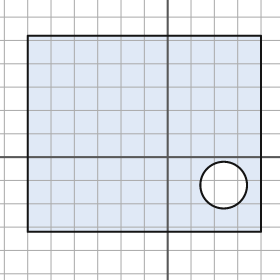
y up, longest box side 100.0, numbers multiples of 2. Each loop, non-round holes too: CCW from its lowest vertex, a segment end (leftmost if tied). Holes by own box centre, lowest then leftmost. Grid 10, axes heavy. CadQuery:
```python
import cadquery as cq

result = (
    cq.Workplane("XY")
    .moveTo(-60.0, -32.0)
    .lineTo(40.0, -32.0)
    .lineTo(40.0, 52.0)
    .lineTo(-60.0, 52.0)
    .close()
    .moveTo(24.0, -12.0)
    .circle(10.0)
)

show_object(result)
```